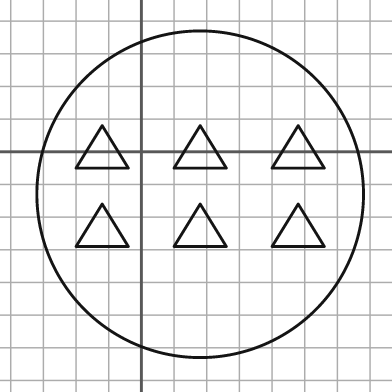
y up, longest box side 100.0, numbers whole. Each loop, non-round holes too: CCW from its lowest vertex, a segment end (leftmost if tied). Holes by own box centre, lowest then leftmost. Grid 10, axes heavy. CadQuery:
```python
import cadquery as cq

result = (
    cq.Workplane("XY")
    .moveTo(18.0, -13.0)
    .circle(50.0)
    .moveTo(-20.0, -29.0)
    .lineTo(-4.0, -29.0)
    .lineTo(-12.0, -16.0)
    .close()
    .moveTo(10.0, -29.0)
    .lineTo(26.0, -29.0)
    .lineTo(18.0, -16.0)
    .close()
    .moveTo(40.0, -29.0)
    .lineTo(56.0, -29.0)
    .lineTo(48.0, -16.0)
    .close()
    .moveTo(-20.0, -5.0)
    .lineTo(-4.0, -5.0)
    .lineTo(-12.0, 8.0)
    .close()
    .moveTo(10.0, -5.0)
    .lineTo(26.0, -5.0)
    .lineTo(18.0, 8.0)
    .close()
    .moveTo(40.0, -5.0)
    .lineTo(56.0, -5.0)
    .lineTo(48.0, 8.0)
    .close()
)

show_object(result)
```